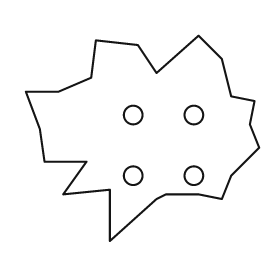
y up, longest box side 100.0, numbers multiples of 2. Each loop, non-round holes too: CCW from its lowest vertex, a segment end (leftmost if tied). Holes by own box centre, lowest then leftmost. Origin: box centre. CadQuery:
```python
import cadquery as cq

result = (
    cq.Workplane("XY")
    .moveTo(-14.0, -44.0)
    .lineTo(6.0, -26.0)
    .lineTo(10.0, -24.0)
    .lineTo(24.0, -24.0)
    .lineTo(34.0, -26.0)
    .lineTo(38.0, -16.0)
    .lineTo(50.0, -4.0)
    .lineTo(46.0, 6.0)
    .lineTo(48.0, 16.0)
    .lineTo(38.0, 18.0)
    .lineTo(34.0, 34.0)
    .lineTo(24.0, 44.0)
    .lineTo(6.0, 28.0)
    .lineTo(-2.0, 40.0)
    .lineTo(-20.0, 42.0)
    .lineTo(-22.0, 26.0)
    .lineTo(-36.0, 20.0)
    .lineTo(-50.0, 20.0)
    .lineTo(-44.0, 4.0)
    .lineTo(-42.0, -10.0)
    .lineTo(-24.0, -10.0)
    .lineTo(-34.0, -24.0)
    .lineTo(-14.0, -22.0)
    .close()
    .moveTo(-4.0, -16.0)
    .circle(4.0)
    .moveTo(22.0, -16.0)
    .circle(4.0)
    .moveTo(-4.0, 10.0)
    .circle(4.0)
    .moveTo(22.0, 10.0)
    .circle(4.0)
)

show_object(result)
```